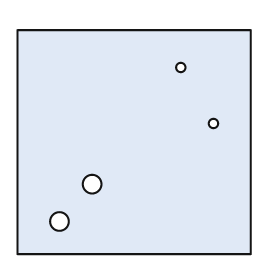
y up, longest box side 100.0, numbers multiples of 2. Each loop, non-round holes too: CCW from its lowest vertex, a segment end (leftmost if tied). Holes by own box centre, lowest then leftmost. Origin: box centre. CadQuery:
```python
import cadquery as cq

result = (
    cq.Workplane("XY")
    .moveTo(-50.0, -48.0)
    .lineTo(50.0, -48.0)
    .lineTo(50.0, 48.0)
    .lineTo(-50.0, 48.0)
    .close()
    .moveTo(-32.0, -34.0)
    .circle(4.0)
    .moveTo(-18.0, -18.0)
    .circle(4.0)
    .moveTo(34.0, 8.0)
    .circle(2.0)
    .moveTo(20.0, 32.0)
    .circle(2.0)
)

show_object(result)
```